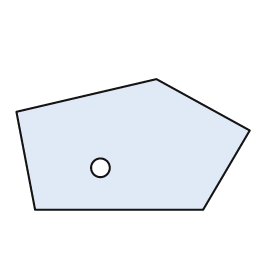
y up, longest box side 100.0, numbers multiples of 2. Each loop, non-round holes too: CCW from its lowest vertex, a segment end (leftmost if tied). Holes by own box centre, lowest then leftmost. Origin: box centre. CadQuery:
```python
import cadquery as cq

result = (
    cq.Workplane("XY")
    .moveTo(-42.0, -28.0)
    .lineTo(30.0, -28.0)
    .lineTo(50.0, 6.0)
    .lineTo(10.0, 28.0)
    .lineTo(-50.0, 14.0)
    .close()
    .moveTo(-14.0, -10.0)
    .circle(4.0)
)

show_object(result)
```